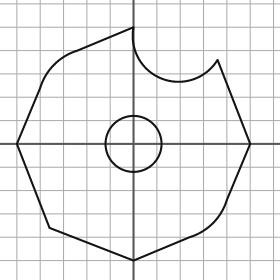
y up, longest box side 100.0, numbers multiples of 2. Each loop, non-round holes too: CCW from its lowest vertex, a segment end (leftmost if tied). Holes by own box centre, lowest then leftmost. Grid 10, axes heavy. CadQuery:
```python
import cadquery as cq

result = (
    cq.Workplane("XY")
    .moveTo(0.0, -50.0)
    .lineTo(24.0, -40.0)
    .threePointArc((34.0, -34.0), (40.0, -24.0))
    .lineTo(50.0, 0.0)
    .lineTo(36.0, 36.0)
    .threePointArc((12.0, 28.0), (0.0, 50.0))
    .lineTo(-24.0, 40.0)
    .threePointArc((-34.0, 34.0), (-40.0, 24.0))
    .lineTo(-50.0, 0.0)
    .lineTo(-36.0, -36.0)
    .close()
    .moveTo(0.0, 0.0)
    .circle(12.0)
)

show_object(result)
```